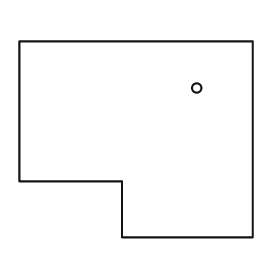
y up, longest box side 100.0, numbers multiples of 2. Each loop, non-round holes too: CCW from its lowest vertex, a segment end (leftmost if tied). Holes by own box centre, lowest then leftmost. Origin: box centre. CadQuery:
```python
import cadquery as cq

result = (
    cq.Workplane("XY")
    .moveTo(-6.0, -42.0)
    .lineTo(50.0, -42.0)
    .lineTo(50.0, 42.0)
    .lineTo(-50.0, 42.0)
    .lineTo(-50.0, -18.0)
    .lineTo(-6.0, -18.0)
    .close()
    .moveTo(26.0, 22.0)
    .circle(2.0)
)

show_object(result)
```